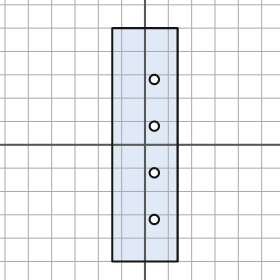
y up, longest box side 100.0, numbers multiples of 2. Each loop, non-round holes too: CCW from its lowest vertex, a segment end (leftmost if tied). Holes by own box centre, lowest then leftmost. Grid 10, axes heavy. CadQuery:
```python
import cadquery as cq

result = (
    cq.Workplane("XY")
    .moveTo(-14.0, -50.0)
    .lineTo(14.0, -50.0)
    .lineTo(14.0, 50.0)
    .lineTo(-14.0, 50.0)
    .close()
    .moveTo(4.0, -32.0)
    .circle(2.0)
    .moveTo(4.0, -12.0)
    .circle(2.0)
    .moveTo(4.0, 8.0)
    .circle(2.0)
    .moveTo(4.0, 28.0)
    .circle(2.0)
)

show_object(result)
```